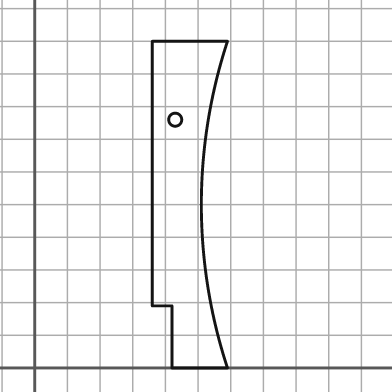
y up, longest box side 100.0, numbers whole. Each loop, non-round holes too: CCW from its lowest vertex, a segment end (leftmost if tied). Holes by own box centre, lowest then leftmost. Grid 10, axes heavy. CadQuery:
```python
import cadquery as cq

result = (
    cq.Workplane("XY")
    .moveTo(42.0, 0.0)
    .lineTo(59.0, 0.0)
    .threePointArc((51.0, 50.0), (59.0, 100.0))
    .lineTo(36.0, 100.0)
    .lineTo(36.0, 19.0)
    .lineTo(42.0, 19.0)
    .close()
    .moveTo(43.0, 76.0)
    .circle(2.0)
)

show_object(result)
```